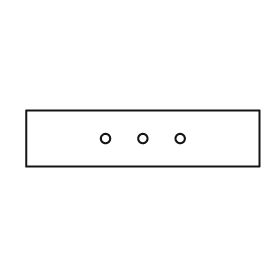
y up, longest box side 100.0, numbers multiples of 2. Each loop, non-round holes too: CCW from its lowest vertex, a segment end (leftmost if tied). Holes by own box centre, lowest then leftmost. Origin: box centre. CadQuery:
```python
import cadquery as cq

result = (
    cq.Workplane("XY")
    .moveTo(-50.0, -12.0)
    .lineTo(50.0, -12.0)
    .lineTo(50.0, 12.0)
    .lineTo(-50.0, 12.0)
    .close()
    .moveTo(-16.0, 0.0)
    .circle(2.0)
    .moveTo(0.0, 0.0)
    .circle(2.0)
    .moveTo(16.0, 0.0)
    .circle(2.0)
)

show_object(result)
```